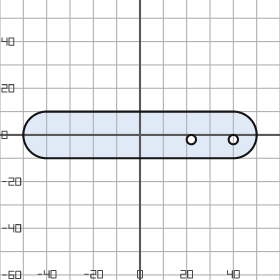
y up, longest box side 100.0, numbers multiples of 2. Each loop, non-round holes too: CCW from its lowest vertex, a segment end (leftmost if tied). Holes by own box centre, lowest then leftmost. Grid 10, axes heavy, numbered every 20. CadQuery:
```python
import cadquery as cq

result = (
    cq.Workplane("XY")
    .moveTo(-40.0, -10.0)
    .lineTo(40.0, -10.0)
    .threePointArc((50.0, 0.0), (40.0, 10.0))
    .lineTo(-40.0, 10.0)
    .threePointArc((-50.0, 0.0), (-40.0, -10.0))
    .close()
    .moveTo(22.0, -2.0)
    .circle(2.0)
    .moveTo(40.0, -2.0)
    .circle(2.0)
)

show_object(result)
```